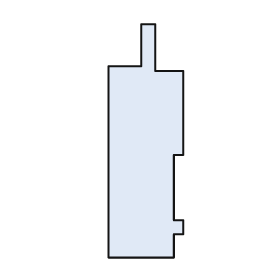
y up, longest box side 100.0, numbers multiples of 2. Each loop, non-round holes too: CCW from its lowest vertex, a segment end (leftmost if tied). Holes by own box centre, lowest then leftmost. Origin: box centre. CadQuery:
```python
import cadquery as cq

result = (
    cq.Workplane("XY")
    .moveTo(-16.0, -50.0)
    .lineTo(12.0, -50.0)
    .lineTo(12.0, -40.0)
    .lineTo(16.0, -40.0)
    .lineTo(16.0, -34.0)
    .lineTo(12.0, -34.0)
    .lineTo(12.0, -6.0)
    .lineTo(16.0, -6.0)
    .lineTo(16.0, 30.0)
    .lineTo(4.0, 30.0)
    .lineTo(4.0, 50.0)
    .lineTo(-2.0, 50.0)
    .lineTo(-2.0, 32.0)
    .lineTo(-16.0, 32.0)
    .close()
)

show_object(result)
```